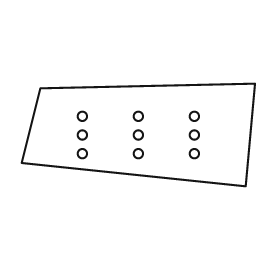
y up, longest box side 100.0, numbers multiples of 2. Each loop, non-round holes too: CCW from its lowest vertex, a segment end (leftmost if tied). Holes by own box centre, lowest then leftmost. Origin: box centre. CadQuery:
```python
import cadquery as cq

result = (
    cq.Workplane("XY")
    .moveTo(46.0, -22.0)
    .lineTo(50.0, 22.0)
    .lineTo(-42.0, 20.0)
    .lineTo(-50.0, -12.0)
    .close()
    .moveTo(-24.0, -8.0)
    .circle(2.0)
    .moveTo(0.0, -8.0)
    .circle(2.0)
    .moveTo(24.0, -8.0)
    .circle(2.0)
    .moveTo(-24.0, 0.0)
    .circle(2.0)
    .moveTo(0.0, 0.0)
    .circle(2.0)
    .moveTo(24.0, 0.0)
    .circle(2.0)
    .moveTo(-24.0, 8.0)
    .circle(2.0)
    .moveTo(0.0, 8.0)
    .circle(2.0)
    .moveTo(24.0, 8.0)
    .circle(2.0)
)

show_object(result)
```